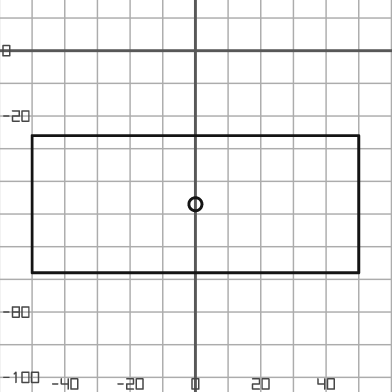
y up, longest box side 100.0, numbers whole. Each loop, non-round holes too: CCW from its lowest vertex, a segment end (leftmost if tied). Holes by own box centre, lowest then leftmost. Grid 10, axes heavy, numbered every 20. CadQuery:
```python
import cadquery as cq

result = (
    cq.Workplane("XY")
    .moveTo(-50.0, -68.0)
    .lineTo(50.0, -68.0)
    .lineTo(50.0, -26.0)
    .lineTo(-50.0, -26.0)
    .close()
    .moveTo(0.0, -47.0)
    .circle(2.0)
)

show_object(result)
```